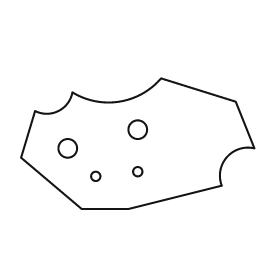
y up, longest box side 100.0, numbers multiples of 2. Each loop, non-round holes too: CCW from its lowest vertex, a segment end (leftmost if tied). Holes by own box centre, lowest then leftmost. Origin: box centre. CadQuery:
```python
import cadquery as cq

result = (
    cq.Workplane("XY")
    .moveTo(-24.0, -28.0)
    .lineTo(-4.0, -28.0)
    .lineTo(36.0, -18.0)
    .threePointArc((38.0, -6.0), (50.0, -2.0))
    .lineTo(42.0, 18.0)
    .lineTo(10.0, 28.0)
    .threePointArc((-8.0, 18.0), (-28.0, 22.0))
    .threePointArc((-34.0, 14.0), (-44.0, 14.0))
    .lineTo(-50.0, -6.0)
    .close()
    .moveTo(-18.0, -14.0)
    .circle(2.0)
    .moveTo(0.0, -12.0)
    .circle(2.0)
    .moveTo(-30.0, -2.0)
    .circle(4.0)
    .moveTo(0.0, 6.0)
    .circle(4.0)
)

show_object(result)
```